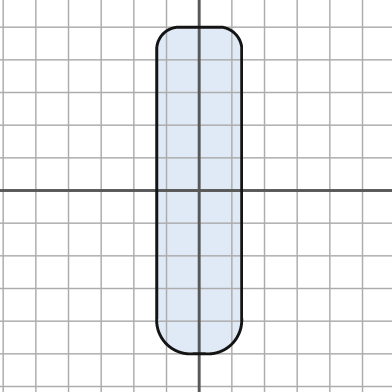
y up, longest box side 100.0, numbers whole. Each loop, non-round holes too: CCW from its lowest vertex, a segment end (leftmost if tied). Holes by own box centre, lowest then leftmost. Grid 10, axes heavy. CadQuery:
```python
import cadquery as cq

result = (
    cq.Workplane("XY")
    .moveTo(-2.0, -50.0)
    .lineTo(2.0, -50.0)
    .threePointArc((10.0, -47.0), (13.0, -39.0))
    .lineTo(13.0, 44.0)
    .threePointArc((11.0, 48.0), (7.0, 50.0))
    .lineTo(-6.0, 50.0)
    .threePointArc((-11.0, 48.0), (-13.0, 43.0))
    .lineTo(-13.0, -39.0)
    .threePointArc((-10.0, -47.0), (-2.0, -50.0))
    .close()
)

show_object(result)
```